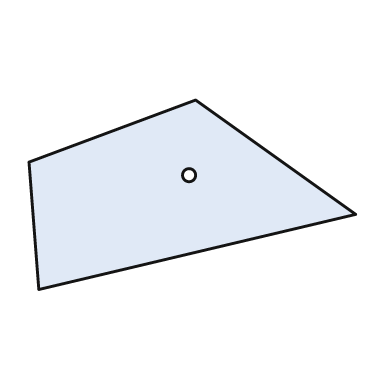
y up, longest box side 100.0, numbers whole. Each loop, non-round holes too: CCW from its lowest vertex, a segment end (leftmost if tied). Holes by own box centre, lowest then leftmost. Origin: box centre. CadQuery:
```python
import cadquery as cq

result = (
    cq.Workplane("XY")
    .moveTo(-47.0, -29.0)
    .lineTo(50.0, -6.0)
    .lineTo(1.0, 29.0)
    .lineTo(-50.0, 10.0)
    .close()
    .moveTo(-1.0, 6.0)
    .circle(2.0)
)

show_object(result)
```